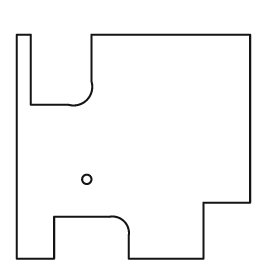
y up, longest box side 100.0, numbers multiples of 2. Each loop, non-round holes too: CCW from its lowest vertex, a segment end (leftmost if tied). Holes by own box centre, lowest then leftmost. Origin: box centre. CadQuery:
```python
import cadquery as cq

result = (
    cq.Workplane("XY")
    .moveTo(-50.0, -48.0)
    .lineTo(-34.0, -48.0)
    .lineTo(-34.0, -30.0)
    .lineTo(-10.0, -30.0)
    .threePointArc((-4.0, -32.0), (-2.0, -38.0))
    .lineTo(-2.0, -48.0)
    .lineTo(30.0, -48.0)
    .lineTo(30.0, -24.0)
    .lineTo(50.0, -24.0)
    .lineTo(50.0, 48.0)
    .lineTo(-18.0, 48.0)
    .lineTo(-18.0, 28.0)
    .threePointArc((-20.0, 20.0), (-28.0, 18.0))
    .lineTo(-44.0, 18.0)
    .lineTo(-44.0, 48.0)
    .lineTo(-50.0, 48.0)
    .close()
    .moveTo(-20.0, -14.0)
    .circle(2.0)
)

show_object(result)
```